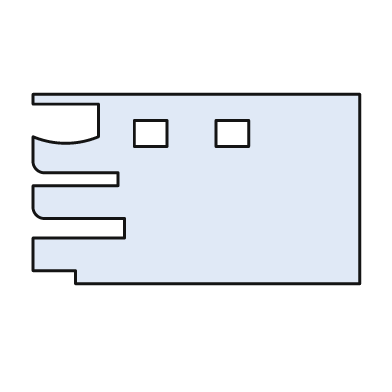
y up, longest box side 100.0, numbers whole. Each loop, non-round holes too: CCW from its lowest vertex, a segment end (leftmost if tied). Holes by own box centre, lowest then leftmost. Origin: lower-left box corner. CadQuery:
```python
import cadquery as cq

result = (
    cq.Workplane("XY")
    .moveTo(13.0, 0.0)
    .lineTo(100.0, 0.0)
    .lineTo(100.0, 58.0)
    .lineTo(0.0, 58.0)
    .lineTo(0.0, 55.0)
    .lineTo(20.0, 55.0)
    .lineTo(20.0, 45.0)
    .threePointArc((10.0, 43.0), (0.0, 45.0))
    .lineTo(0.0, 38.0)
    .threePointArc((1.0, 35.0), (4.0, 34.0))
    .lineTo(26.0, 34.0)
    .lineTo(26.0, 30.0)
    .lineTo(0.0, 30.0)
    .lineTo(0.0, 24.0)
    .threePointArc((1.0, 21.0), (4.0, 20.0))
    .lineTo(28.0, 20.0)
    .lineTo(28.0, 14.0)
    .lineTo(0.0, 14.0)
    .lineTo(0.0, 4.0)
    .lineTo(13.0, 4.0)
    .close()
    .moveTo(31.0, 42.0)
    .lineTo(41.0, 42.0)
    .lineTo(41.0, 50.0)
    .lineTo(31.0, 50.0)
    .close()
    .moveTo(56.0, 42.0)
    .lineTo(66.0, 42.0)
    .lineTo(66.0, 50.0)
    .lineTo(56.0, 50.0)
    .close()
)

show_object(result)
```